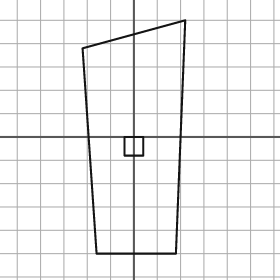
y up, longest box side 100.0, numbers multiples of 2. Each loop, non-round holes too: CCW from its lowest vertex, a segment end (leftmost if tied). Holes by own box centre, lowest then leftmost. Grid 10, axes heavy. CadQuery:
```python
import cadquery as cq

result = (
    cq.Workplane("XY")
    .moveTo(-16.0, -50.0)
    .lineTo(18.0, -50.0)
    .lineTo(22.0, 50.0)
    .lineTo(-22.0, 38.0)
    .close()
    .moveTo(-4.0, -8.0)
    .lineTo(4.0, -8.0)
    .lineTo(4.0, 0.0)
    .lineTo(-4.0, 0.0)
    .close()
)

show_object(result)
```